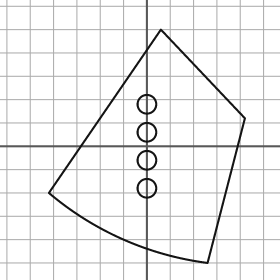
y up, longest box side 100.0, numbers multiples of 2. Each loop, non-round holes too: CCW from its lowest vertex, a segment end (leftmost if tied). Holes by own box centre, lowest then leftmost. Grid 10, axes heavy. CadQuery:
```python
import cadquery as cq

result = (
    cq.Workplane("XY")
    .moveTo(26.0, -50.0)
    .lineTo(42.0, 12.0)
    .lineTo(6.0, 50.0)
    .lineTo(-42.0, -20.0)
    .threePointArc((-10.0, -40.0), (26.0, -50.0))
    .close()
    .moveTo(0.0, -18.0)
    .circle(4.0)
    .moveTo(0.0, -6.0)
    .circle(4.0)
    .moveTo(0.0, 6.0)
    .circle(4.0)
    .moveTo(0.0, 18.0)
    .circle(4.0)
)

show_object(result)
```